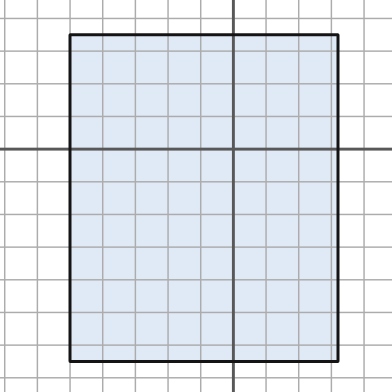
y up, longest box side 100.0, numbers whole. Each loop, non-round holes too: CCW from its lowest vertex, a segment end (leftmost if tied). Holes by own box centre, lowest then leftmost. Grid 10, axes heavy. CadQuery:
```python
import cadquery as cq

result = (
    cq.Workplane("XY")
    .moveTo(-50.0, -65.0)
    .lineTo(32.0, -65.0)
    .lineTo(32.0, 35.0)
    .lineTo(-50.0, 35.0)
    .close()
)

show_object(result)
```